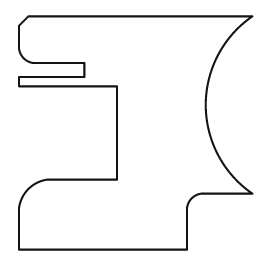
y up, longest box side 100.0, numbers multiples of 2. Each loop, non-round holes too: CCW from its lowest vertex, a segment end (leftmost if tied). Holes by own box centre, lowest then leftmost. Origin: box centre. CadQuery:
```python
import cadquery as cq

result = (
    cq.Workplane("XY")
    .moveTo(-50.0, -50.0)
    .lineTo(22.0, -50.0)
    .lineTo(22.0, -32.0)
    .threePointArc((24.0, -28.0), (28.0, -26.0))
    .lineTo(50.0, -26.0)
    .threePointArc((30.0, 12.0), (50.0, 50.0))
    .lineTo(-46.0, 50.0)
    .lineTo(-50.0, 46.0)
    .lineTo(-50.0, 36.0)
    .threePointArc((-48.0, 32.0), (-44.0, 30.0))
    .lineTo(-22.0, 30.0)
    .lineTo(-22.0, 24.0)
    .lineTo(-50.0, 24.0)
    .lineTo(-50.0, 20.0)
    .lineTo(-8.0, 20.0)
    .lineTo(-8.0, -20.0)
    .lineTo(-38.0, -20.0)
    .threePointArc((-46.0, -24.0), (-50.0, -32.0))
    .close()
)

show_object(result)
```